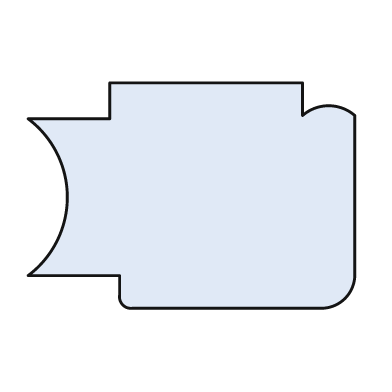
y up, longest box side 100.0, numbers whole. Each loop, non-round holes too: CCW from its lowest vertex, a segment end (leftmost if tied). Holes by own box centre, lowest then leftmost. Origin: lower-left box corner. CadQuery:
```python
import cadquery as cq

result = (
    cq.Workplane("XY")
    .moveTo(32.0, 0.0)
    .lineTo(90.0, 0.0)
    .threePointArc((97.0, 3.0), (100.0, 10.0))
    .lineTo(100.0, 59.0)
    .threePointArc((92.0, 62.0), (84.0, 59.0))
    .lineTo(84.0, 69.0)
    .lineTo(25.0, 69.0)
    .lineTo(25.0, 58.0)
    .lineTo(0.0, 58.0)
    .threePointArc((12.0, 34.0), (0.0, 10.0))
    .lineTo(28.0, 10.0)
    .lineTo(28.0, 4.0)
    .threePointArc((29.0, 1.0), (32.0, 0.0))
    .close()
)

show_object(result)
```